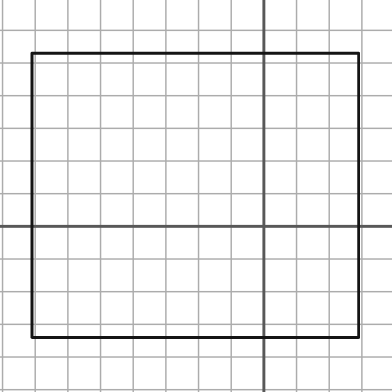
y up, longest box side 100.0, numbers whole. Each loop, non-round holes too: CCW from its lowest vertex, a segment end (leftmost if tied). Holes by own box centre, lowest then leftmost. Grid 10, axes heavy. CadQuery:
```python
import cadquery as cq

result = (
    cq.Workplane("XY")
    .moveTo(-71.0, -34.0)
    .lineTo(29.0, -34.0)
    .lineTo(29.0, 53.0)
    .lineTo(-71.0, 53.0)
    .close()
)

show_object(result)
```